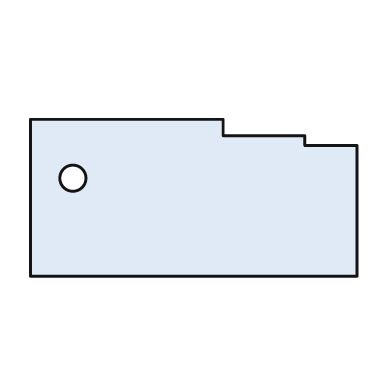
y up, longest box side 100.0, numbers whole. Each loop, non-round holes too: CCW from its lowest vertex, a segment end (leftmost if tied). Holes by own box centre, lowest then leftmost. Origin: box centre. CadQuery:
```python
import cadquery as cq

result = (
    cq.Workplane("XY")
    .moveTo(-50.0, -24.0)
    .lineTo(50.0, -24.0)
    .lineTo(50.0, 16.0)
    .lineTo(34.0, 16.0)
    .lineTo(34.0, 19.0)
    .lineTo(9.0, 19.0)
    .lineTo(9.0, 24.0)
    .lineTo(-50.0, 24.0)
    .close()
    .moveTo(-37.0, 6.0)
    .circle(4.0)
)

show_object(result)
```